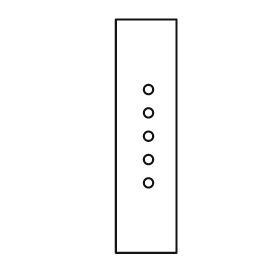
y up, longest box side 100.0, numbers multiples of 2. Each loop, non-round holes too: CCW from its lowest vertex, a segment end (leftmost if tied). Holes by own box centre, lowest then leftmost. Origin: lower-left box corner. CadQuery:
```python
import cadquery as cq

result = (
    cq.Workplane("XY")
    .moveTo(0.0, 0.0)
    .lineTo(26.0, 0.0)
    .lineTo(26.0, 100.0)
    .lineTo(0.0, 100.0)
    .close()
    .moveTo(14.0, 30.0)
    .circle(2.0)
    .moveTo(14.0, 40.0)
    .circle(2.0)
    .moveTo(14.0, 50.0)
    .circle(2.0)
    .moveTo(14.0, 60.0)
    .circle(2.0)
    .moveTo(14.0, 70.0)
    .circle(2.0)
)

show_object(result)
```